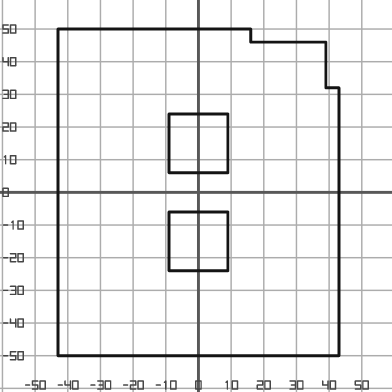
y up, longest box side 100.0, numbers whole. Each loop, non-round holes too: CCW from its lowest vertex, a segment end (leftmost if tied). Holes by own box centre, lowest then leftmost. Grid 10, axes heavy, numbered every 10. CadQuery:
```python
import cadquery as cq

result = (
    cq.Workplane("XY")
    .moveTo(-43.0, -50.0)
    .lineTo(43.0, -50.0)
    .lineTo(43.0, 32.0)
    .lineTo(39.0, 32.0)
    .lineTo(39.0, 46.0)
    .lineTo(16.0, 46.0)
    .lineTo(16.0, 50.0)
    .lineTo(-43.0, 50.0)
    .close()
    .moveTo(-9.0, -24.0)
    .lineTo(9.0, -24.0)
    .lineTo(9.0, -6.0)
    .lineTo(-9.0, -6.0)
    .close()
    .moveTo(-9.0, 6.0)
    .lineTo(9.0, 6.0)
    .lineTo(9.0, 24.0)
    .lineTo(-9.0, 24.0)
    .close()
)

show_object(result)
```